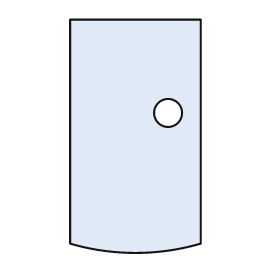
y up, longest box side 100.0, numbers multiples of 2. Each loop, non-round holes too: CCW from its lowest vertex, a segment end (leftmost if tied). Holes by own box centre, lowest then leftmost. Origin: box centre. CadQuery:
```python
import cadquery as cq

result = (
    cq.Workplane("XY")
    .moveTo(-28.0, -46.0)
    .threePointArc((0.0, -50.0), (28.0, -46.0))
    .lineTo(28.0, 50.0)
    .lineTo(-28.0, 50.0)
    .close()
    .moveTo(14.0, 10.0)
    .circle(6.0)
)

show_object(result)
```